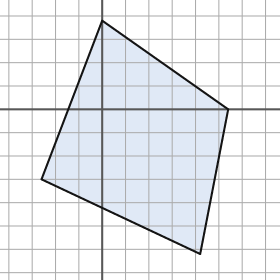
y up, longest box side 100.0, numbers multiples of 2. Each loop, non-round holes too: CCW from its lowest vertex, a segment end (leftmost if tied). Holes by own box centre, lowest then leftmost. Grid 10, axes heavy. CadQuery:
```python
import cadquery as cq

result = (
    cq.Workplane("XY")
    .moveTo(42.0, -62.0)
    .lineTo(54.0, 0.0)
    .lineTo(0.0, 38.0)
    .lineTo(-26.0, -30.0)
    .close()
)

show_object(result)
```